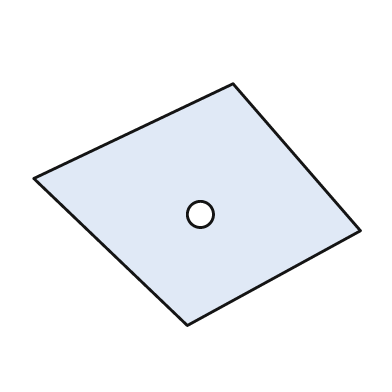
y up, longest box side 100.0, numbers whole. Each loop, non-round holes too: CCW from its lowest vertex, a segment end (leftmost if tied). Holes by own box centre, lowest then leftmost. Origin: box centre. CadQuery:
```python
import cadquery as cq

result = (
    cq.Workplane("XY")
    .moveTo(-3.0, -37.0)
    .lineTo(50.0, -8.0)
    .lineTo(11.0, 37.0)
    .lineTo(-50.0, 8.0)
    .close()
    .moveTo(1.0, -3.0)
    .circle(4.0)
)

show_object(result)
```